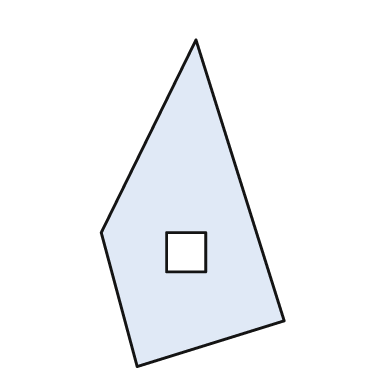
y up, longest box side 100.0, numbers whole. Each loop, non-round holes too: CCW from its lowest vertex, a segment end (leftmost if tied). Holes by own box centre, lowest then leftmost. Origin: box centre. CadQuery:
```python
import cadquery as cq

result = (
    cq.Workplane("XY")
    .moveTo(-17.0, -50.0)
    .lineTo(28.0, -36.0)
    .lineTo(1.0, 50.0)
    .lineTo(-28.0, -9.0)
    .close()
    .moveTo(-8.0, -21.0)
    .lineTo(4.0, -21.0)
    .lineTo(4.0, -9.0)
    .lineTo(-8.0, -9.0)
    .close()
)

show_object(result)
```